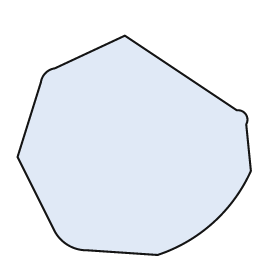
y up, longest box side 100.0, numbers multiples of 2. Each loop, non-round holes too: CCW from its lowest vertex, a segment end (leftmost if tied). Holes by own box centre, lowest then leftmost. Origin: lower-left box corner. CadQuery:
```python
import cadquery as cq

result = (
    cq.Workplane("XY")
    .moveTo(60.0, 0.0)
    .threePointArc((84.0, 14.0), (100.0, 36.0))
    .lineTo(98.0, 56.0)
    .threePointArc((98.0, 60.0), (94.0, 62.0))
    .lineTo(46.0, 94.0)
    .lineTo(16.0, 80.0)
    .threePointArc((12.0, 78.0), (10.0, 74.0))
    .lineTo(0.0, 42.0)
    .lineTo(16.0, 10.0)
    .threePointArc((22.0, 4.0), (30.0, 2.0))
    .close()
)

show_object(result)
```